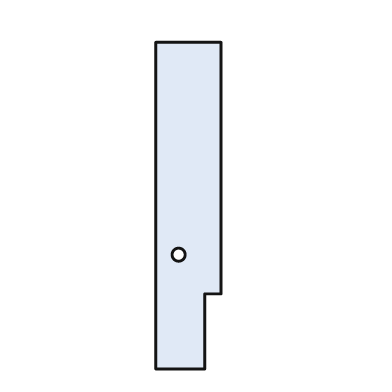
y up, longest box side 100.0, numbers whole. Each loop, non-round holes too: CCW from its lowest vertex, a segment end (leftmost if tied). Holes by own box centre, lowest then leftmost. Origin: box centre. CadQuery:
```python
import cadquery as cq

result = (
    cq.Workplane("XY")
    .moveTo(-10.0, -50.0)
    .lineTo(5.0, -50.0)
    .lineTo(5.0, -27.0)
    .lineTo(10.0, -27.0)
    .lineTo(10.0, 50.0)
    .lineTo(-10.0, 50.0)
    .close()
    .moveTo(-3.0, -15.0)
    .circle(2.0)
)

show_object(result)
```